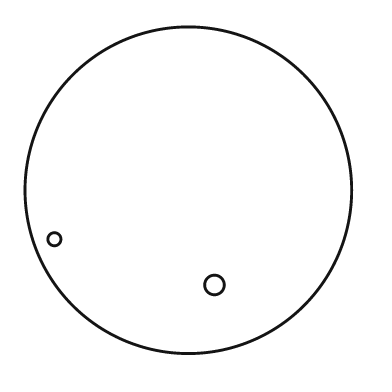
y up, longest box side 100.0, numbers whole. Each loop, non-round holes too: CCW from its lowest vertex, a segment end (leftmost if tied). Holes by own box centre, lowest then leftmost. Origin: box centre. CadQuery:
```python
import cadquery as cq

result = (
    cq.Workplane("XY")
    .moveTo(0.0, 0.0)
    .circle(50.0)
    .moveTo(8.0, -29.0)
    .circle(3.0)
    .moveTo(-41.0, -15.0)
    .circle(2.0)
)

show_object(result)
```